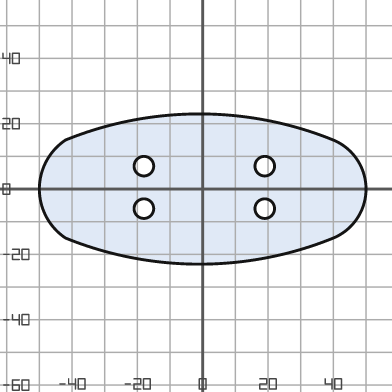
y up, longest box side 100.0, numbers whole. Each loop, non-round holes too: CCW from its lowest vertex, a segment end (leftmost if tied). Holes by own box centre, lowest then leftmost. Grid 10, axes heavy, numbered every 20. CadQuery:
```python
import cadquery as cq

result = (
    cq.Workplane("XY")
    .moveTo(-42.0, -15.0)
    .threePointArc((-1.0, -23.0), (40.0, -15.0))
    .threePointArc((50.0, 0.0), (40.0, 15.0))
    .threePointArc((-1.0, 23.0), (-42.0, 15.0))
    .threePointArc((-50.0, 0.0), (-42.0, -15.0))
    .close()
    .moveTo(-18.0, -6.0)
    .circle(3.0)
    .moveTo(19.0, -6.0)
    .circle(3.0)
    .moveTo(-18.0, 7.0)
    .circle(3.0)
    .moveTo(19.0, 7.0)
    .circle(3.0)
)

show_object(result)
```